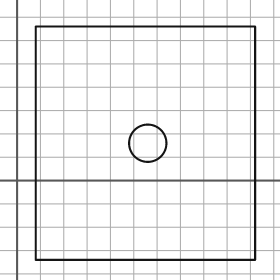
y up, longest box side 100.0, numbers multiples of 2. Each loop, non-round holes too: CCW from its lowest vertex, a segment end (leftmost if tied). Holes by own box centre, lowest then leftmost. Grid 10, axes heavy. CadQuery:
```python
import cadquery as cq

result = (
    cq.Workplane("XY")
    .moveTo(8.0, -34.0)
    .lineTo(102.0, -34.0)
    .lineTo(102.0, 66.0)
    .lineTo(8.0, 66.0)
    .close()
    .moveTo(56.0, 16.0)
    .circle(8.0)
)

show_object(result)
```